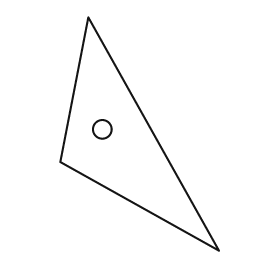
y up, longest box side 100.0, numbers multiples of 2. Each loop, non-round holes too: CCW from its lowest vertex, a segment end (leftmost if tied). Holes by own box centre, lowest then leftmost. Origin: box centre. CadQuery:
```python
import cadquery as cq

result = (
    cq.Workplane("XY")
    .moveTo(34.0, -50.0)
    .lineTo(-22.0, 50.0)
    .lineTo(-34.0, -12.0)
    .close()
    .moveTo(-16.0, 2.0)
    .circle(4.0)
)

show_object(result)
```